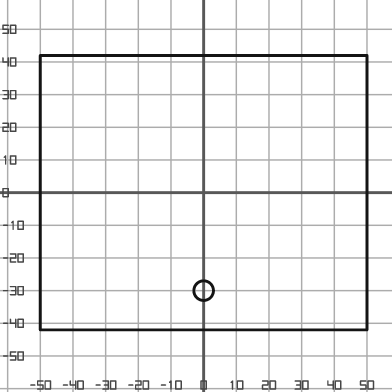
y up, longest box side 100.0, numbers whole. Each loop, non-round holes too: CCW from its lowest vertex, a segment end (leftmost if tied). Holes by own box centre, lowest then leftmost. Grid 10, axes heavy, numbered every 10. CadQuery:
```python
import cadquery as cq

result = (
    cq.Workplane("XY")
    .moveTo(-50.0, -42.0)
    .lineTo(50.0, -42.0)
    .lineTo(50.0, 42.0)
    .lineTo(-50.0, 42.0)
    .close()
    .moveTo(0.0, -30.0)
    .circle(3.0)
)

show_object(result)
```